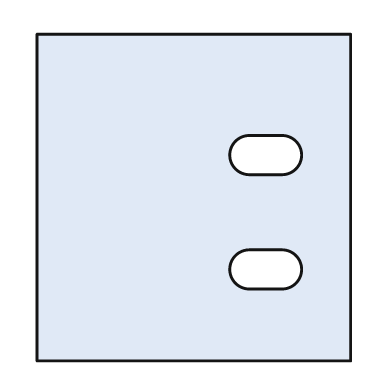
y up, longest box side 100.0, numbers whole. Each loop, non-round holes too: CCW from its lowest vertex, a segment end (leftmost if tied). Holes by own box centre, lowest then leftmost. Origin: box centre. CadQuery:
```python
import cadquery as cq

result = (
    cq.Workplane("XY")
    .moveTo(-48.0, -50.0)
    .lineTo(48.0, -50.0)
    .lineTo(48.0, 50.0)
    .lineTo(-48.0, 50.0)
    .close()
    .moveTo(17.0, -28.0)
    .lineTo(27.0, -28.0)
    .threePointArc((33.0, -22.0), (27.0, -16.0))
    .lineTo(17.0, -16.0)
    .threePointArc((11.0, -22.0), (17.0, -28.0))
    .close()
    .moveTo(17.0, 7.0)
    .lineTo(27.0, 7.0)
    .threePointArc((33.0, 13.0), (27.0, 19.0))
    .lineTo(17.0, 19.0)
    .threePointArc((11.0, 13.0), (17.0, 7.0))
    .close()
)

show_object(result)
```